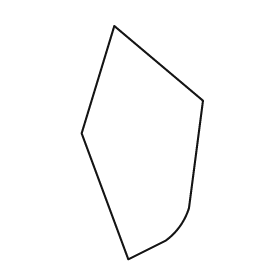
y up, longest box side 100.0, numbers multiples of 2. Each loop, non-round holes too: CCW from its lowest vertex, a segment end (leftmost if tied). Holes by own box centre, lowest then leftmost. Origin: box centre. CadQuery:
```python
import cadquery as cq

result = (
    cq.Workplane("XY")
    .moveTo(-6.0, -50.0)
    .lineTo(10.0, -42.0)
    .threePointArc((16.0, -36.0), (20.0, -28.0))
    .lineTo(26.0, 18.0)
    .lineTo(-12.0, 50.0)
    .lineTo(-26.0, 4.0)
    .close()
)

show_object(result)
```